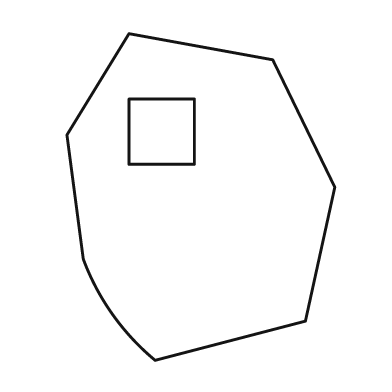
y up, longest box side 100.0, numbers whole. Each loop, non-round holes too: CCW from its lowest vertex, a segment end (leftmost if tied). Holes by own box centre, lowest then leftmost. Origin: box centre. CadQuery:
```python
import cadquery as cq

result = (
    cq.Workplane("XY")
    .moveTo(-14.0, -50.0)
    .lineTo(32.0, -38.0)
    .lineTo(41.0, 3.0)
    .lineTo(22.0, 42.0)
    .lineTo(-22.0, 50.0)
    .lineTo(-41.0, 19.0)
    .lineTo(-36.0, -19.0)
    .threePointArc((-27.0, -36.0), (-14.0, -50.0))
    .close()
    .moveTo(-22.0, 10.0)
    .lineTo(-2.0, 10.0)
    .lineTo(-2.0, 30.0)
    .lineTo(-22.0, 30.0)
    .close()
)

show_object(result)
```